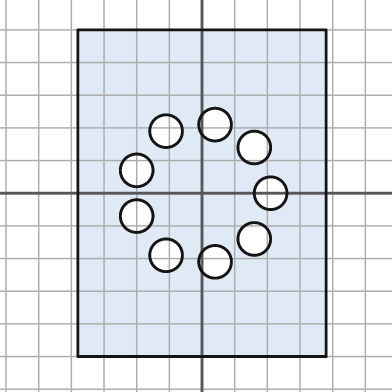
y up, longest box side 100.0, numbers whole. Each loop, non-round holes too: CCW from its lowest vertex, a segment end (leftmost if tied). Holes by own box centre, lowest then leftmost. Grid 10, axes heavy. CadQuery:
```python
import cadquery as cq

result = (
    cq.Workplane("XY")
    .moveTo(-38.0, -50.0)
    .lineTo(38.0, -50.0)
    .lineTo(38.0, 50.0)
    .lineTo(-38.0, 50.0)
    .close()
    .moveTo(4.0, -21.0)
    .circle(5.0)
    .moveTo(-11.0, -19.0)
    .circle(5.0)
    .moveTo(16.0, -14.0)
    .circle(5.0)
    .moveTo(-20.0, -7.0)
    .circle(5.0)
    .moveTo(21.0, 0.0)
    .circle(5.0)
    .moveTo(-20.0, 7.0)
    .circle(5.0)
    .moveTo(16.0, 14.0)
    .circle(5.0)
    .moveTo(-11.0, 19.0)
    .circle(5.0)
    .moveTo(4.0, 21.0)
    .circle(5.0)
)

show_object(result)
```